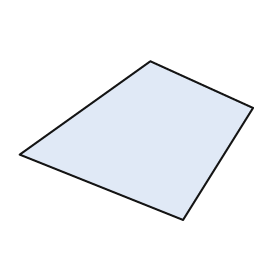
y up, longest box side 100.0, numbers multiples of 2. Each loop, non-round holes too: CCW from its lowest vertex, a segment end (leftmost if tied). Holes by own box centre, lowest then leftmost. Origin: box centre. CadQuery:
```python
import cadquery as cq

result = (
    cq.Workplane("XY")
    .moveTo(20.0, -34.0)
    .lineTo(50.0, 14.0)
    .lineTo(6.0, 34.0)
    .lineTo(-50.0, -6.0)
    .close()
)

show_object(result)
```